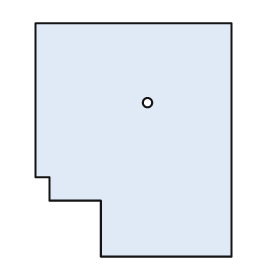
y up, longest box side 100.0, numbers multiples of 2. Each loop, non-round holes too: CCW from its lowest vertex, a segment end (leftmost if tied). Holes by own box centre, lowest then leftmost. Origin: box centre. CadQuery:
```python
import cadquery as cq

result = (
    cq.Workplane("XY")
    .moveTo(-14.0, -50.0)
    .lineTo(42.0, -50.0)
    .lineTo(42.0, 50.0)
    .lineTo(-42.0, 50.0)
    .lineTo(-42.0, -16.0)
    .lineTo(-36.0, -16.0)
    .lineTo(-36.0, -26.0)
    .lineTo(-14.0, -26.0)
    .close()
    .moveTo(6.0, 16.0)
    .circle(2.0)
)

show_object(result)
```